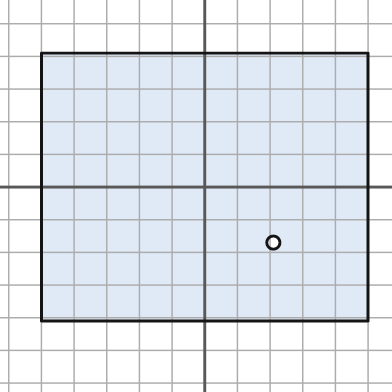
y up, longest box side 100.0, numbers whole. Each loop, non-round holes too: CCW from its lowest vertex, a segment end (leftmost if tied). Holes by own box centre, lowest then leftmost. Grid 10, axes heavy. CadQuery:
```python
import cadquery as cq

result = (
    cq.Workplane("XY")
    .moveTo(-50.0, -41.0)
    .lineTo(50.0, -41.0)
    .lineTo(50.0, 41.0)
    .lineTo(-50.0, 41.0)
    .close()
    .moveTo(21.0, -17.0)
    .circle(2.0)
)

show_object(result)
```